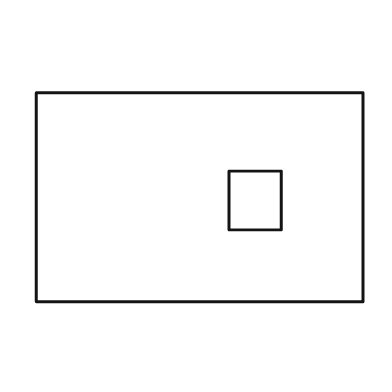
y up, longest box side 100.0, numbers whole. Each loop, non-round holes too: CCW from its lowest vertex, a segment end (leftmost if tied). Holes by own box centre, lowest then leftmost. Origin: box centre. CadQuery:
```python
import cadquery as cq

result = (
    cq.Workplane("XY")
    .moveTo(-50.0, -32.0)
    .lineTo(50.0, -32.0)
    .lineTo(50.0, 32.0)
    .lineTo(-50.0, 32.0)
    .close()
    .moveTo(9.0, -10.0)
    .lineTo(25.0, -10.0)
    .lineTo(25.0, 8.0)
    .lineTo(9.0, 8.0)
    .close()
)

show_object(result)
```